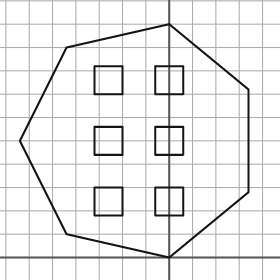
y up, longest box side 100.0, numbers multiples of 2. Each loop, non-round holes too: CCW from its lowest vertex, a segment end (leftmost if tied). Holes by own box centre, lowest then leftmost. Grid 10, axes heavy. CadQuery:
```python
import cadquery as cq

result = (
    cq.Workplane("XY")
    .moveTo(0.0, 0.0)
    .lineTo(34.0, 28.0)
    .lineTo(34.0, 72.0)
    .lineTo(0.0, 100.0)
    .lineTo(-44.0, 90.0)
    .lineTo(-64.0, 50.0)
    .lineTo(-44.0, 10.0)
    .close()
    .moveTo(-32.0, 18.0)
    .lineTo(-20.0, 18.0)
    .lineTo(-20.0, 30.0)
    .lineTo(-32.0, 30.0)
    .close()
    .moveTo(-6.0, 18.0)
    .lineTo(6.0, 18.0)
    .lineTo(6.0, 30.0)
    .lineTo(-6.0, 30.0)
    .close()
    .moveTo(-32.0, 44.0)
    .lineTo(-20.0, 44.0)
    .lineTo(-20.0, 56.0)
    .lineTo(-32.0, 56.0)
    .close()
    .moveTo(-6.0, 44.0)
    .lineTo(6.0, 44.0)
    .lineTo(6.0, 56.0)
    .lineTo(-6.0, 56.0)
    .close()
    .moveTo(-32.0, 70.0)
    .lineTo(-20.0, 70.0)
    .lineTo(-20.0, 82.0)
    .lineTo(-32.0, 82.0)
    .close()
    .moveTo(-6.0, 70.0)
    .lineTo(6.0, 70.0)
    .lineTo(6.0, 82.0)
    .lineTo(-6.0, 82.0)
    .close()
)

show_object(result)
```